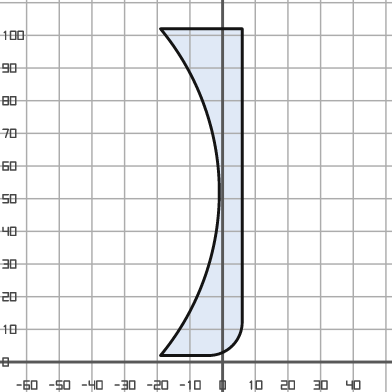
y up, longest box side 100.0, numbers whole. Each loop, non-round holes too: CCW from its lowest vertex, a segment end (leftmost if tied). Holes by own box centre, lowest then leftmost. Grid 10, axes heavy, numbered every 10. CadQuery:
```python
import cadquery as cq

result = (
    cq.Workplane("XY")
    .moveTo(-19.0, 2.0)
    .lineTo(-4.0, 2.0)
    .threePointArc((3.0, 5.0), (6.0, 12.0))
    .lineTo(6.0, 102.0)
    .lineTo(-19.0, 102.0)
    .threePointArc((-1.0, 52.0), (-19.0, 2.0))
    .close()
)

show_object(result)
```